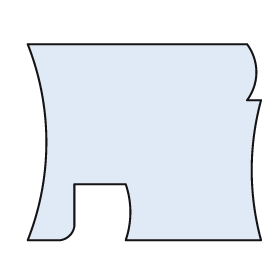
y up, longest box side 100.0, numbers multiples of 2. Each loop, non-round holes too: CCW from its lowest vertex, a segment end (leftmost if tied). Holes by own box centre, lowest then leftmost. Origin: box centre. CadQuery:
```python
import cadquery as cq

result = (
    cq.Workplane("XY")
    .moveTo(-50.0, -42.0)
    .lineTo(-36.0, -42.0)
    .threePointArc((-32.0, -40.0), (-30.0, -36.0))
    .lineTo(-30.0, -18.0)
    .lineTo(-8.0, -18.0)
    .threePointArc((-6.0, -30.0), (-8.0, -42.0))
    .lineTo(50.0, -42.0)
    .threePointArc((46.0, -12.0), (50.0, 18.0))
    .lineTo(44.0, 18.0)
    .threePointArc((48.0, 30.0), (44.0, 42.0))
    .lineTo(-50.0, 42.0)
    .threePointArc((-42.0, 0.0), (-50.0, -42.0))
    .close()
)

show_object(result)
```